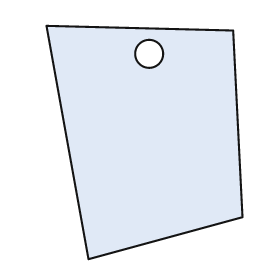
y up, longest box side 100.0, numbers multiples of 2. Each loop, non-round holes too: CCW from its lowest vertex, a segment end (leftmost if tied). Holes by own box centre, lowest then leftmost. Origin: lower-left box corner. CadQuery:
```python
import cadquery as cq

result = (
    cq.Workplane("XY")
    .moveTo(18.0, 0.0)
    .lineTo(84.0, 18.0)
    .lineTo(80.0, 98.0)
    .lineTo(0.0, 100.0)
    .close()
    .moveTo(44.0, 88.0)
    .circle(6.0)
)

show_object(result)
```